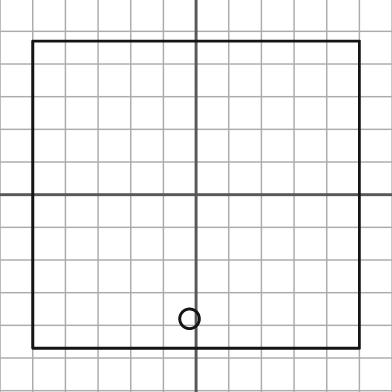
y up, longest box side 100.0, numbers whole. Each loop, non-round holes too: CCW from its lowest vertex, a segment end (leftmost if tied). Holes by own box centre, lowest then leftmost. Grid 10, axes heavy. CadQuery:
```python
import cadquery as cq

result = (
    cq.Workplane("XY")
    .moveTo(-50.0, -47.0)
    .lineTo(50.0, -47.0)
    .lineTo(50.0, 47.0)
    .lineTo(-50.0, 47.0)
    .close()
    .moveTo(-2.0, -38.0)
    .circle(3.0)
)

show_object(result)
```